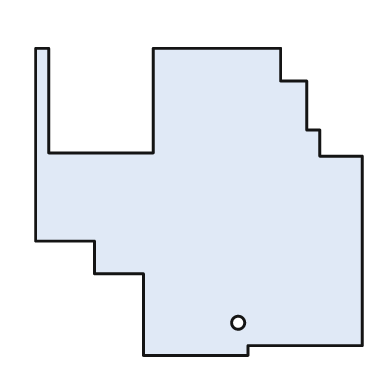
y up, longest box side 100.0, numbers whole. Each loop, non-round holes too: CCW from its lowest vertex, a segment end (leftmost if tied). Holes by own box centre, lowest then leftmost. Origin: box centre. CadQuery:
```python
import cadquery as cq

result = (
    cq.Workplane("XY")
    .moveTo(-17.0, -47.0)
    .lineTo(15.0, -47.0)
    .lineTo(15.0, -44.0)
    .lineTo(50.0, -44.0)
    .lineTo(50.0, 14.0)
    .lineTo(37.0, 14.0)
    .lineTo(37.0, 22.0)
    .lineTo(33.0, 22.0)
    .lineTo(33.0, 37.0)
    .lineTo(25.0, 37.0)
    .lineTo(25.0, 47.0)
    .lineTo(-14.0, 47.0)
    .lineTo(-14.0, 15.0)
    .lineTo(-46.0, 15.0)
    .lineTo(-46.0, 47.0)
    .lineTo(-50.0, 47.0)
    .lineTo(-50.0, -12.0)
    .lineTo(-32.0, -12.0)
    .lineTo(-32.0, -22.0)
    .lineTo(-17.0, -22.0)
    .close()
    .moveTo(12.0, -37.0)
    .circle(2.0)
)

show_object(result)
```